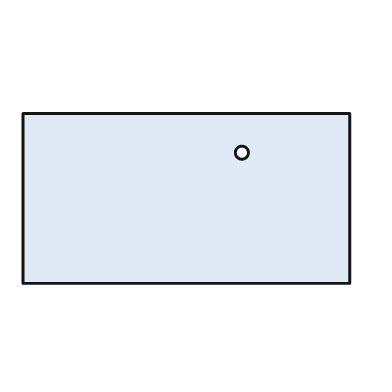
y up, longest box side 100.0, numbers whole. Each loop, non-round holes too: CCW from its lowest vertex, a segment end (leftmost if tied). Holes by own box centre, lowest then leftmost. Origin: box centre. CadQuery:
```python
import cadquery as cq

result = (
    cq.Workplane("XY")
    .moveTo(-50.0, -26.0)
    .lineTo(50.0, -26.0)
    .lineTo(50.0, 26.0)
    .lineTo(-50.0, 26.0)
    .close()
    .moveTo(17.0, 14.0)
    .circle(2.0)
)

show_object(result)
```